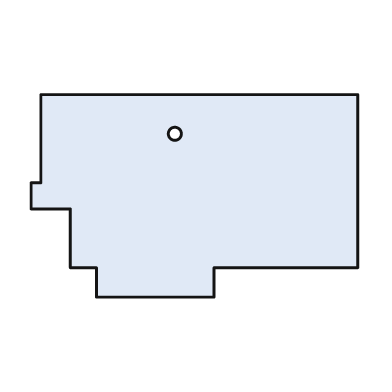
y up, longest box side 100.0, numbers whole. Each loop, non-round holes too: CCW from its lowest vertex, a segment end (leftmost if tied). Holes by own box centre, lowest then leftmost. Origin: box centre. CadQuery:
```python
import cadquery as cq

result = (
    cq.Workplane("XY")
    .moveTo(-30.0, -31.0)
    .lineTo(6.0, -31.0)
    .lineTo(6.0, -22.0)
    .lineTo(50.0, -22.0)
    .lineTo(50.0, 31.0)
    .lineTo(-47.0, 31.0)
    .lineTo(-47.0, 4.0)
    .lineTo(-50.0, 4.0)
    .lineTo(-50.0, -4.0)
    .lineTo(-38.0, -4.0)
    .lineTo(-38.0, -22.0)
    .lineTo(-30.0, -22.0)
    .close()
    .moveTo(-6.0, 19.0)
    .circle(2.0)
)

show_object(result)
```